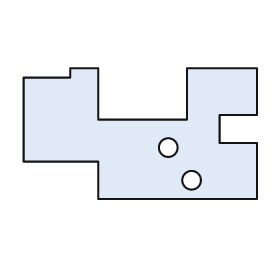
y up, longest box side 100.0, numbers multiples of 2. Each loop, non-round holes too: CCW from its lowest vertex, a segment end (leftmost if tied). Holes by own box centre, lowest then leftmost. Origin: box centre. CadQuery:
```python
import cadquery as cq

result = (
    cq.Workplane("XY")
    .moveTo(-18.0, -28.0)
    .lineTo(50.0, -28.0)
    .lineTo(50.0, -4.0)
    .lineTo(34.0, -4.0)
    .lineTo(34.0, 8.0)
    .lineTo(50.0, 8.0)
    .lineTo(50.0, 28.0)
    .lineTo(20.0, 28.0)
    .lineTo(20.0, 6.0)
    .lineTo(-18.0, 6.0)
    .lineTo(-18.0, 28.0)
    .lineTo(-30.0, 28.0)
    .lineTo(-30.0, 24.0)
    .lineTo(-50.0, 24.0)
    .lineTo(-50.0, -12.0)
    .lineTo(-18.0, -12.0)
    .close()
    .moveTo(22.0, -20.0)
    .circle(4.0)
    .moveTo(12.0, -6.0)
    .circle(4.0)
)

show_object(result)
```